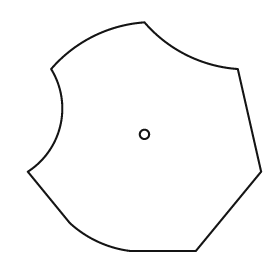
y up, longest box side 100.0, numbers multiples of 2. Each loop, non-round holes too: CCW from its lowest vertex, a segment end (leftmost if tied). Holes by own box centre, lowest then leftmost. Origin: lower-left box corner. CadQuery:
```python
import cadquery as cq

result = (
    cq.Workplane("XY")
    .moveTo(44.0, 0.0)
    .lineTo(72.0, 0.0)
    .lineTo(100.0, 34.0)
    .lineTo(90.0, 78.0)
    .threePointArc((68.0, 84.0), (50.0, 98.0))
    .threePointArc((28.0, 92.0), (10.0, 78.0))
    .threePointArc((14.0, 54.0), (0.0, 34.0))
    .lineTo(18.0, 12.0)
    .threePointArc((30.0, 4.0), (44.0, 0.0))
    .close()
    .moveTo(50.0, 50.0)
    .circle(2.0)
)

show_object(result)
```